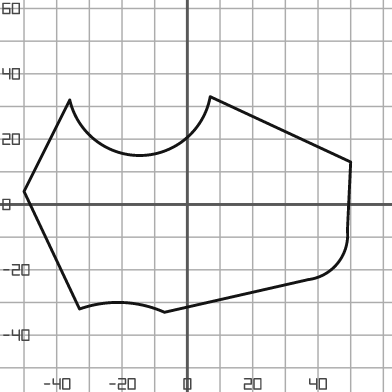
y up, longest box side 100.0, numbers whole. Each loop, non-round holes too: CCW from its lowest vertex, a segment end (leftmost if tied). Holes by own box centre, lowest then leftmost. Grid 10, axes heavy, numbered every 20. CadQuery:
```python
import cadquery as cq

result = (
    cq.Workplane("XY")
    .moveTo(-7.0, -33.0)
    .lineTo(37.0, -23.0)
    .threePointArc((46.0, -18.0), (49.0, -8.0))
    .lineTo(50.0, 13.0)
    .lineTo(7.0, 33.0)
    .threePointArc((-14.0, 15.0), (-36.0, 32.0))
    .lineTo(-50.0, 4.0)
    .lineTo(-33.0, -32.0)
    .threePointArc((-20.0, -30.0), (-7.0, -33.0))
    .close()
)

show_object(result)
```